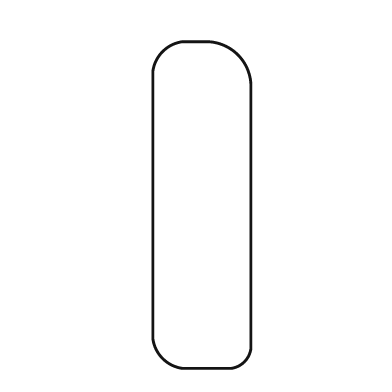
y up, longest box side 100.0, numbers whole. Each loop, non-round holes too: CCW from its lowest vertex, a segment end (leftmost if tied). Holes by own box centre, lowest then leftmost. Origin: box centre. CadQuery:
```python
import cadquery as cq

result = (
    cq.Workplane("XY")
    .moveTo(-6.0, -50.0)
    .lineTo(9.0, -50.0)
    .threePointArc((13.0, -48.0), (15.0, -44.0))
    .lineTo(15.0, 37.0)
    .threePointArc((11.0, 46.0), (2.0, 50.0))
    .lineTo(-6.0, 50.0)
    .threePointArc((-12.0, 47.0), (-15.0, 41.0))
    .lineTo(-15.0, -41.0)
    .threePointArc((-12.0, -47.0), (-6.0, -50.0))
    .close()
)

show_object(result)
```